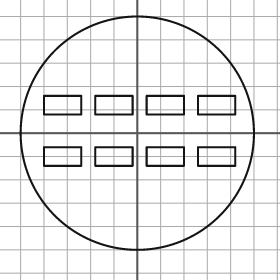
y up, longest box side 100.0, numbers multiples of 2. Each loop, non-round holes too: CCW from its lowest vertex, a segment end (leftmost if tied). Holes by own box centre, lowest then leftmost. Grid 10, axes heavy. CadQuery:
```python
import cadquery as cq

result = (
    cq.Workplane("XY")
    .moveTo(0.0, 0.0)
    .circle(50.0)
    .moveTo(-40.0, -14.0)
    .lineTo(-24.0, -14.0)
    .lineTo(-24.0, -6.0)
    .lineTo(-40.0, -6.0)
    .close()
    .moveTo(-18.0, -14.0)
    .lineTo(-2.0, -14.0)
    .lineTo(-2.0, -6.0)
    .lineTo(-18.0, -6.0)
    .close()
    .moveTo(4.0, -14.0)
    .lineTo(20.0, -14.0)
    .lineTo(20.0, -6.0)
    .lineTo(4.0, -6.0)
    .close()
    .moveTo(26.0, -14.0)
    .lineTo(42.0, -14.0)
    .lineTo(42.0, -6.0)
    .lineTo(26.0, -6.0)
    .close()
    .moveTo(-40.0, 8.0)
    .lineTo(-24.0, 8.0)
    .lineTo(-24.0, 16.0)
    .lineTo(-40.0, 16.0)
    .close()
    .moveTo(-18.0, 8.0)
    .lineTo(-2.0, 8.0)
    .lineTo(-2.0, 16.0)
    .lineTo(-18.0, 16.0)
    .close()
    .moveTo(4.0, 8.0)
    .lineTo(20.0, 8.0)
    .lineTo(20.0, 16.0)
    .lineTo(4.0, 16.0)
    .close()
    .moveTo(26.0, 8.0)
    .lineTo(42.0, 8.0)
    .lineTo(42.0, 16.0)
    .lineTo(26.0, 16.0)
    .close()
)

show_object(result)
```